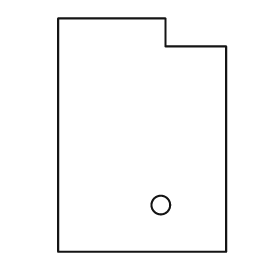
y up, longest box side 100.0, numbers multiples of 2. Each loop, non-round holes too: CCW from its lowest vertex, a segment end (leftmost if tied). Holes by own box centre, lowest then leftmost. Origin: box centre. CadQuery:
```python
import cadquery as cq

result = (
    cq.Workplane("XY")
    .moveTo(-36.0, -50.0)
    .lineTo(36.0, -50.0)
    .lineTo(36.0, 38.0)
    .lineTo(10.0, 38.0)
    .lineTo(10.0, 50.0)
    .lineTo(-36.0, 50.0)
    .close()
    .moveTo(8.0, -30.0)
    .circle(4.0)
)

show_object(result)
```